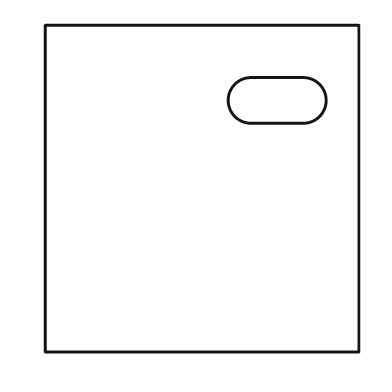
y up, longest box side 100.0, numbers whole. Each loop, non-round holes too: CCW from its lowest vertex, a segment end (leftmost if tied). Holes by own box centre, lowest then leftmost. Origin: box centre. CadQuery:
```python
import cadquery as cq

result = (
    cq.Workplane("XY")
    .moveTo(-48.0, -50.0)
    .lineTo(48.0, -50.0)
    .lineTo(48.0, 50.0)
    .lineTo(-48.0, 50.0)
    .close()
    .moveTo(15.0, 20.0)
    .lineTo(31.0, 20.0)
    .threePointArc((38.0, 27.0), (31.0, 34.0))
    .lineTo(15.0, 34.0)
    .threePointArc((8.0, 27.0), (15.0, 20.0))
    .close()
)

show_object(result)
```